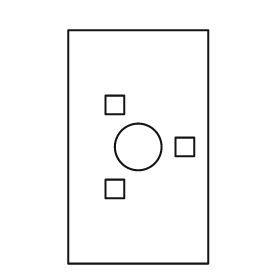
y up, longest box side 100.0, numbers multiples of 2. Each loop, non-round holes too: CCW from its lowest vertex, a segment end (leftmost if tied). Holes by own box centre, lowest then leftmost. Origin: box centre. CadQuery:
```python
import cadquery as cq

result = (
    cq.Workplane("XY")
    .moveTo(-30.0, -50.0)
    .lineTo(30.0, -50.0)
    .lineTo(30.0, 50.0)
    .lineTo(-30.0, 50.0)
    .close()
    .moveTo(-14.0, -22.0)
    .lineTo(-6.0, -22.0)
    .lineTo(-6.0, -14.0)
    .lineTo(-14.0, -14.0)
    .close()
    .moveTo(0.0, 0.0)
    .circle(10.0)
    .moveTo(16.0, -4.0)
    .lineTo(24.0, -4.0)
    .lineTo(24.0, 4.0)
    .lineTo(16.0, 4.0)
    .close()
    .moveTo(-14.0, 14.0)
    .lineTo(-6.0, 14.0)
    .lineTo(-6.0, 22.0)
    .lineTo(-14.0, 22.0)
    .close()
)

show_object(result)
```